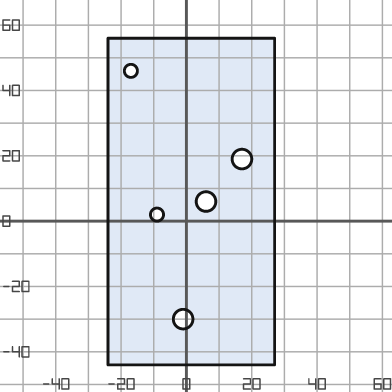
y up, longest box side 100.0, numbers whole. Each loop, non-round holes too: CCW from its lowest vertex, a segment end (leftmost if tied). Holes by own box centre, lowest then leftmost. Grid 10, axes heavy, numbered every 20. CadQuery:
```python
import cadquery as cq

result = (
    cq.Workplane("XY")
    .moveTo(-24.0, -44.0)
    .lineTo(27.0, -44.0)
    .lineTo(27.0, 56.0)
    .lineTo(-24.0, 56.0)
    .close()
    .moveTo(-1.0, -30.0)
    .circle(3.0)
    .moveTo(-9.0, 2.0)
    .circle(2.0)
    .moveTo(6.0, 6.0)
    .circle(3.0)
    .moveTo(17.0, 19.0)
    .circle(3.0)
    .moveTo(-17.0, 46.0)
    .circle(2.0)
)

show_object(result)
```